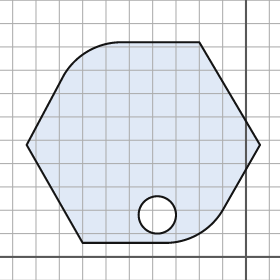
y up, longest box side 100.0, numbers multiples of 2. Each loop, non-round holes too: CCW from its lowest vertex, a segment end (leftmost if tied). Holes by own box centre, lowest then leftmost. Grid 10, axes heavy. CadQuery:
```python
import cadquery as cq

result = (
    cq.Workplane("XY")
    .moveTo(-70.0, 6.0)
    .lineTo(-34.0, 6.0)
    .threePointArc((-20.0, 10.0), (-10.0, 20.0))
    .lineTo(6.0, 48.0)
    .lineTo(-20.0, 92.0)
    .lineTo(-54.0, 92.0)
    .threePointArc((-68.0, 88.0), (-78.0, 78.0))
    .lineTo(-94.0, 48.0)
    .close()
    .moveTo(-38.0, 18.0)
    .circle(8.0)
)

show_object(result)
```